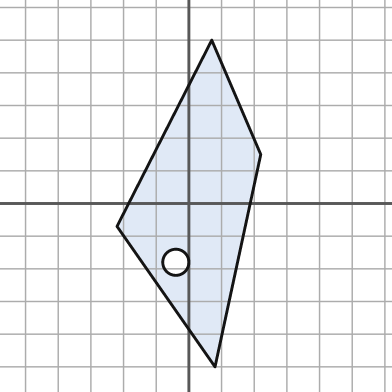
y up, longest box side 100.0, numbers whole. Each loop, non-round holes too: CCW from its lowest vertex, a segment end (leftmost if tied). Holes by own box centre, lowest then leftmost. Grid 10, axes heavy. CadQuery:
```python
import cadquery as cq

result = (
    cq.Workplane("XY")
    .moveTo(8.0, -50.0)
    .lineTo(22.0, 15.0)
    .lineTo(7.0, 50.0)
    .lineTo(-22.0, -7.0)
    .close()
    .moveTo(-4.0, -18.0)
    .circle(4.0)
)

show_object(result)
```